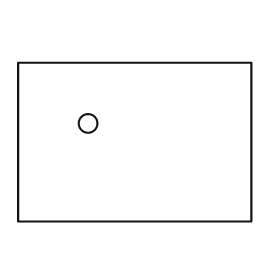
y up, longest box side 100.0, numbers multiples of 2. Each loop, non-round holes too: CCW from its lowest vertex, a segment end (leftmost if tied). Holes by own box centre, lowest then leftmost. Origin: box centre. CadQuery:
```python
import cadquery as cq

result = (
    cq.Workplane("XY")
    .moveTo(-50.0, -34.0)
    .lineTo(50.0, -34.0)
    .lineTo(50.0, 34.0)
    .lineTo(-50.0, 34.0)
    .close()
    .moveTo(-20.0, 8.0)
    .circle(4.0)
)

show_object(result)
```